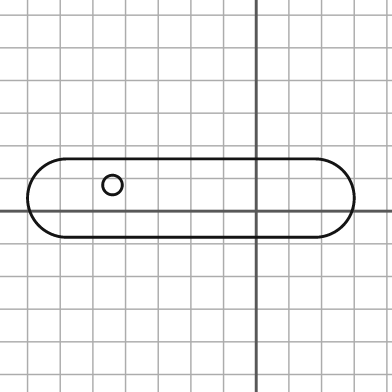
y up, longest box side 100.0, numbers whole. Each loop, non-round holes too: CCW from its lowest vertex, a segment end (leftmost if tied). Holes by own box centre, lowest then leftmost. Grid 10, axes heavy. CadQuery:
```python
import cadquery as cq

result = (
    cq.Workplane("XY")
    .moveTo(-58.0, -8.0)
    .lineTo(18.0, -8.0)
    .threePointArc((30.0, 4.0), (18.0, 16.0))
    .lineTo(-58.0, 16.0)
    .threePointArc((-70.0, 4.0), (-58.0, -8.0))
    .close()
    .moveTo(-44.0, 8.0)
    .circle(3.0)
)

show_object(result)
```